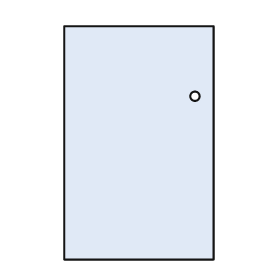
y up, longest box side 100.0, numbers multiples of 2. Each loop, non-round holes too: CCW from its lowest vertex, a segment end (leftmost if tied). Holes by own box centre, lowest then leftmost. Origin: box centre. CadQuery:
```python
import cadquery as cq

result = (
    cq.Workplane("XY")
    .moveTo(-32.0, -50.0)
    .lineTo(32.0, -50.0)
    .lineTo(32.0, 50.0)
    .lineTo(-32.0, 50.0)
    .close()
    .moveTo(24.0, 20.0)
    .circle(2.0)
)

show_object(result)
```